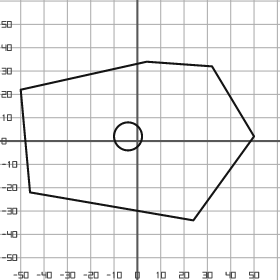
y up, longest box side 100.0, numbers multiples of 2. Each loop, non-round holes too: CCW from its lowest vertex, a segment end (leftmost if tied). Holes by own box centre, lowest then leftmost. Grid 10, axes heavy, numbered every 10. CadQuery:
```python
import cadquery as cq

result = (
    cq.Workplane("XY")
    .moveTo(24.0, -34.0)
    .lineTo(50.0, 2.0)
    .lineTo(32.0, 32.0)
    .lineTo(4.0, 34.0)
    .lineTo(-50.0, 22.0)
    .lineTo(-46.0, -22.0)
    .close()
    .moveTo(-4.0, 2.0)
    .circle(6.0)
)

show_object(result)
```